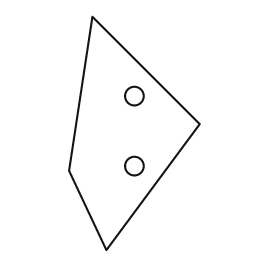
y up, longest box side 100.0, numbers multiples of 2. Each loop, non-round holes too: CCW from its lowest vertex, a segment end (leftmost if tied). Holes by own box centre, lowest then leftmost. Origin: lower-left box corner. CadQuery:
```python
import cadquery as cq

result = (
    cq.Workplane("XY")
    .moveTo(16.0, 0.0)
    .lineTo(56.0, 54.0)
    .lineTo(10.0, 100.0)
    .lineTo(0.0, 34.0)
    .close()
    .moveTo(28.0, 36.0)
    .circle(4.0)
    .moveTo(28.0, 66.0)
    .circle(4.0)
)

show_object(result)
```